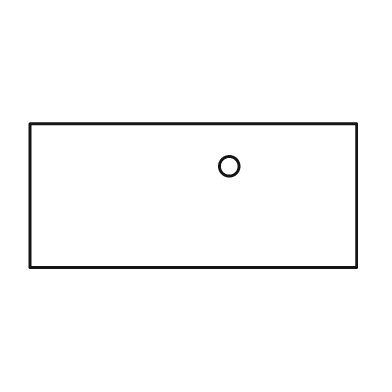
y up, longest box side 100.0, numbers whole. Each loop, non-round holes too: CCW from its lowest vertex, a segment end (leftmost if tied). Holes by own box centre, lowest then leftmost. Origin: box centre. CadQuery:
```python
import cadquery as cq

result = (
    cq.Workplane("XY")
    .moveTo(-50.0, -22.0)
    .lineTo(50.0, -22.0)
    .lineTo(50.0, 22.0)
    .lineTo(-50.0, 22.0)
    .close()
    .moveTo(11.0, 9.0)
    .circle(3.0)
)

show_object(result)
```